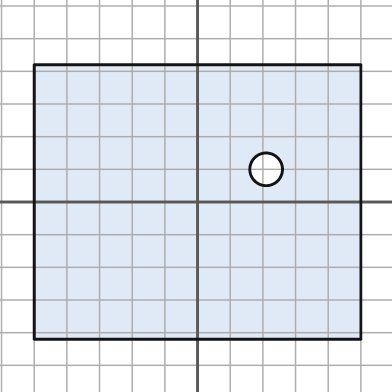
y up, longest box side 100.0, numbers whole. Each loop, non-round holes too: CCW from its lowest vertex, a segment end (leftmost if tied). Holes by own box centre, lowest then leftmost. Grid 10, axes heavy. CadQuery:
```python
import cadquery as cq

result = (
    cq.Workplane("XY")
    .moveTo(-50.0, -42.0)
    .lineTo(50.0, -42.0)
    .lineTo(50.0, 42.0)
    .lineTo(-50.0, 42.0)
    .close()
    .moveTo(21.0, 10.0)
    .circle(5.0)
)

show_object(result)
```